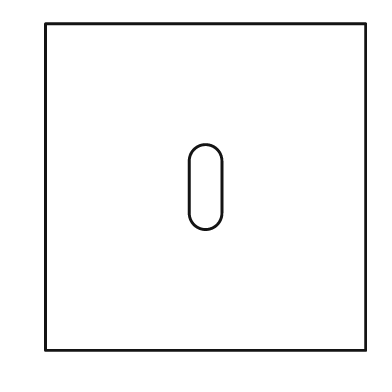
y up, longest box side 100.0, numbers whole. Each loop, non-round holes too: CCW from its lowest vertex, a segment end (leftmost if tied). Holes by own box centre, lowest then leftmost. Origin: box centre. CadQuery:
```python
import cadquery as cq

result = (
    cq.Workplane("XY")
    .moveTo(-49.0, -50.0)
    .lineTo(49.0, -50.0)
    .lineTo(49.0, 50.0)
    .lineTo(-49.0, 50.0)
    .close()
    .moveTo(-5.0, -8.0)
    .threePointArc((0.0, -13.0), (5.0, -8.0))
    .lineTo(5.0, 8.0)
    .threePointArc((0.0, 13.0), (-5.0, 8.0))
    .close()
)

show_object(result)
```